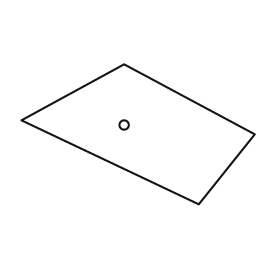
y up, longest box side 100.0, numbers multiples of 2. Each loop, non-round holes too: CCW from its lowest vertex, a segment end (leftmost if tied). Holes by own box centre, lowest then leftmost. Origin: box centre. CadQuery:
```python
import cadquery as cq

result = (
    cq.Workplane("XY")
    .moveTo(26.0, -30.0)
    .lineTo(50.0, 0.0)
    .lineTo(-6.0, 30.0)
    .lineTo(-50.0, 6.0)
    .close()
    .moveTo(-6.0, 4.0)
    .circle(2.0)
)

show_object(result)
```